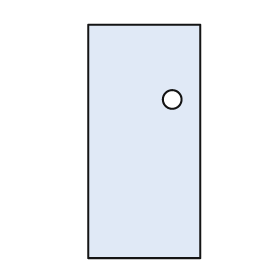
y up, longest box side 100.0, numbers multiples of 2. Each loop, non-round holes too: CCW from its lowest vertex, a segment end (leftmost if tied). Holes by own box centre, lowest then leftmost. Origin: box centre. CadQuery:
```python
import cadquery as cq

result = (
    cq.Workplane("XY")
    .moveTo(-24.0, -50.0)
    .lineTo(24.0, -50.0)
    .lineTo(24.0, 50.0)
    .lineTo(-24.0, 50.0)
    .close()
    .moveTo(12.0, 18.0)
    .circle(4.0)
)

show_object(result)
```